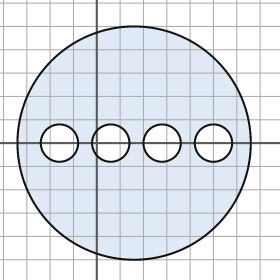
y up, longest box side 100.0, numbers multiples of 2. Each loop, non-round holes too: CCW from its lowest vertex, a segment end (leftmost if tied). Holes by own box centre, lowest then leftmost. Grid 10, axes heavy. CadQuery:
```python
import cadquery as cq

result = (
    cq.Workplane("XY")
    .moveTo(16.0, 0.0)
    .circle(50.0)
    .moveTo(-16.0, 0.0)
    .circle(8.0)
    .moveTo(6.0, 0.0)
    .circle(8.0)
    .moveTo(28.0, 0.0)
    .circle(8.0)
    .moveTo(50.0, 0.0)
    .circle(8.0)
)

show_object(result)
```